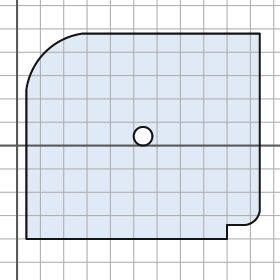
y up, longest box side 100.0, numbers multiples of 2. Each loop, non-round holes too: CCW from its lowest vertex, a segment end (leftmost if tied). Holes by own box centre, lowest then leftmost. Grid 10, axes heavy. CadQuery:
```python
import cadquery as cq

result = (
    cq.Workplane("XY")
    .moveTo(4.0, -40.0)
    .lineTo(90.0, -40.0)
    .lineTo(90.0, -34.0)
    .lineTo(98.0, -34.0)
    .threePointArc((102.0, -32.0), (104.0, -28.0))
    .lineTo(104.0, 48.0)
    .lineTo(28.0, 48.0)
    .threePointArc((12.0, 40.0), (4.0, 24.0))
    .close()
    .moveTo(54.0, 4.0)
    .circle(4.0)
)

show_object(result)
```